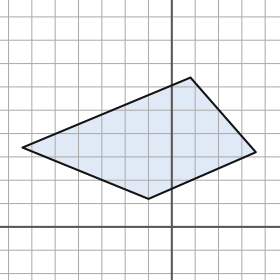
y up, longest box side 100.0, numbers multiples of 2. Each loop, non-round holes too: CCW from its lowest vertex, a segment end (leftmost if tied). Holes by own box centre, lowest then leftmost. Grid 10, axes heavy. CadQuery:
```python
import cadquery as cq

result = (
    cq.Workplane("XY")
    .moveTo(-10.0, 12.0)
    .lineTo(36.0, 32.0)
    .lineTo(8.0, 64.0)
    .lineTo(-64.0, 34.0)
    .close()
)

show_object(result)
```